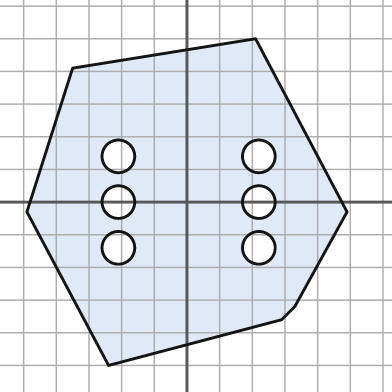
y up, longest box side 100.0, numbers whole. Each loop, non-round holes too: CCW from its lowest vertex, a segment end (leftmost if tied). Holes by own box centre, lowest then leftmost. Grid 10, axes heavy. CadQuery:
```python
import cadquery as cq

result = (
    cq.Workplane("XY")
    .moveTo(-24.0, -50.0)
    .lineTo(29.0, -36.0)
    .lineTo(33.0, -32.0)
    .lineTo(49.0, -3.0)
    .lineTo(21.0, 50.0)
    .lineTo(-35.0, 41.0)
    .lineTo(-49.0, -3.0)
    .close()
    .moveTo(-21.0, -14.0)
    .circle(5.0)
    .moveTo(22.0, -14.0)
    .circle(5.0)
    .moveTo(-21.0, 0.0)
    .circle(5.0)
    .moveTo(22.0, 0.0)
    .circle(5.0)
    .moveTo(-21.0, 14.0)
    .circle(5.0)
    .moveTo(22.0, 14.0)
    .circle(5.0)
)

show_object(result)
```